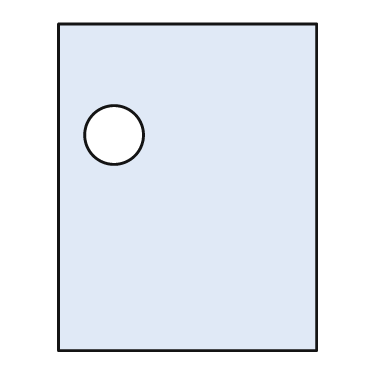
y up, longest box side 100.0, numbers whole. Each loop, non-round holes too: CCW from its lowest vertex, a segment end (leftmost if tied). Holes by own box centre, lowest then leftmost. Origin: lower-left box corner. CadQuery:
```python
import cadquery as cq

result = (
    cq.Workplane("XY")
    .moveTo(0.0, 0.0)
    .lineTo(79.0, 0.0)
    .lineTo(79.0, 100.0)
    .lineTo(0.0, 100.0)
    .close()
    .moveTo(17.0, 66.0)
    .circle(9.0)
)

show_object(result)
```